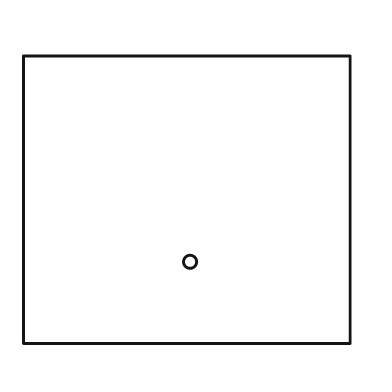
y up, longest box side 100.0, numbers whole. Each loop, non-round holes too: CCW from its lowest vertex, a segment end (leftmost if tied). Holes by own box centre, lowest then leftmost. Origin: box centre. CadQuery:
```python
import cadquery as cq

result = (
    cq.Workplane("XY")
    .moveTo(-50.0, -44.0)
    .lineTo(50.0, -44.0)
    .lineTo(50.0, 44.0)
    .lineTo(-50.0, 44.0)
    .close()
    .moveTo(1.0, -19.0)
    .circle(2.0)
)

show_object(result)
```